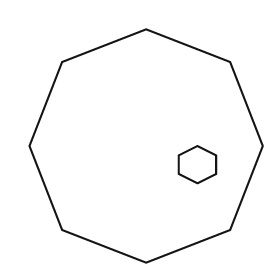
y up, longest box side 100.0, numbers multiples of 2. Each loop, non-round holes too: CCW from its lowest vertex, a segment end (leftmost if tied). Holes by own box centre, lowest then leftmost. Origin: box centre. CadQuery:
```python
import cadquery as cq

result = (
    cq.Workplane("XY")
    .moveTo(0.0, -50.0)
    .lineTo(36.0, -36.0)
    .lineTo(50.0, 0.0)
    .lineTo(36.0, 36.0)
    .lineTo(0.0, 50.0)
    .lineTo(-36.0, 36.0)
    .lineTo(-50.0, 0.0)
    .lineTo(-36.0, -36.0)
    .close()
    .moveTo(22.0, -16.0)
    .lineTo(30.0, -12.0)
    .lineTo(30.0, -4.0)
    .lineTo(22.0, 0.0)
    .lineTo(14.0, -4.0)
    .lineTo(14.0, -12.0)
    .close()
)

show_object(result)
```